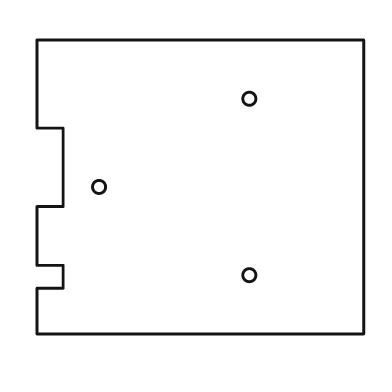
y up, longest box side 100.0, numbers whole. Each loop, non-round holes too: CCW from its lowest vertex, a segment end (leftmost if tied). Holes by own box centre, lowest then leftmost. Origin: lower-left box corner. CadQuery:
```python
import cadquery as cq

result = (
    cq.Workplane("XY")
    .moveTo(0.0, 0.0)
    .lineTo(100.0, 0.0)
    .lineTo(100.0, 90.0)
    .lineTo(0.0, 90.0)
    .lineTo(0.0, 63.0)
    .lineTo(8.0, 63.0)
    .lineTo(8.0, 39.0)
    .lineTo(0.0, 39.0)
    .lineTo(0.0, 21.0)
    .lineTo(8.0, 21.0)
    .lineTo(8.0, 14.0)
    .lineTo(0.0, 14.0)
    .close()
    .moveTo(65.0, 18.0)
    .circle(2.0)
    .moveTo(19.0, 45.0)
    .circle(2.0)
    .moveTo(65.0, 72.0)
    .circle(2.0)
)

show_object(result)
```